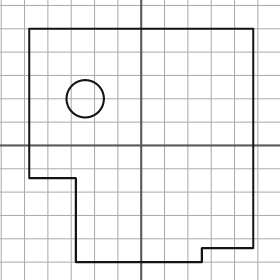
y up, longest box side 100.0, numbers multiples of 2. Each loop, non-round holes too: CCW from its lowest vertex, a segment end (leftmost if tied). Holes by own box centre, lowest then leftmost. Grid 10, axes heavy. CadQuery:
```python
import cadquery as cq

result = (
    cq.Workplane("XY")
    .moveTo(-28.0, -50.0)
    .lineTo(26.0, -50.0)
    .lineTo(26.0, -44.0)
    .lineTo(48.0, -44.0)
    .lineTo(48.0, 50.0)
    .lineTo(-48.0, 50.0)
    .lineTo(-48.0, -14.0)
    .lineTo(-28.0, -14.0)
    .close()
    .moveTo(-24.0, 20.0)
    .circle(8.0)
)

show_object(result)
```